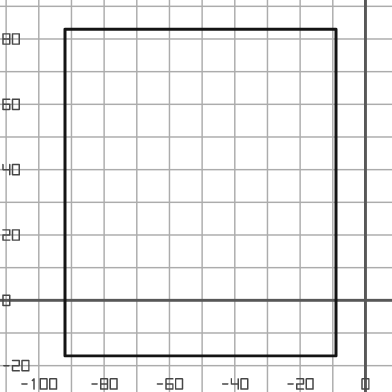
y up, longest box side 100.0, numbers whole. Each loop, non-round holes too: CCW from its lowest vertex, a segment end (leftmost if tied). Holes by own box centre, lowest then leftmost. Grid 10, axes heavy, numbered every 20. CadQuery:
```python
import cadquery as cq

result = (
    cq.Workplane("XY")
    .moveTo(-92.0, -17.0)
    .lineTo(-9.0, -17.0)
    .lineTo(-9.0, 83.0)
    .lineTo(-92.0, 83.0)
    .close()
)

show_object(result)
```